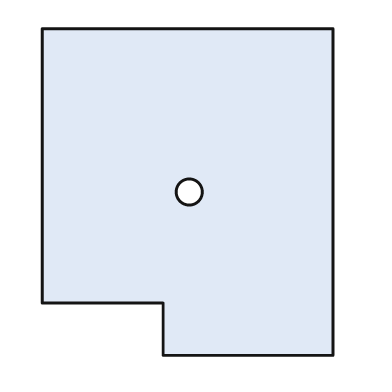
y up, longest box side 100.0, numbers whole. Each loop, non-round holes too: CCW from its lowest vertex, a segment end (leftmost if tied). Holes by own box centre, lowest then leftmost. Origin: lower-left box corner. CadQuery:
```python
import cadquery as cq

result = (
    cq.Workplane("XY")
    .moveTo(37.0, 0.0)
    .lineTo(89.0, 0.0)
    .lineTo(89.0, 100.0)
    .lineTo(0.0, 100.0)
    .lineTo(0.0, 16.0)
    .lineTo(37.0, 16.0)
    .close()
    .moveTo(45.0, 50.0)
    .circle(4.0)
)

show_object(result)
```